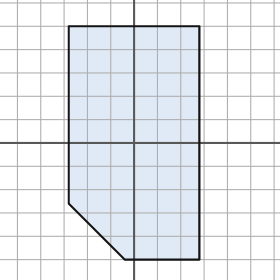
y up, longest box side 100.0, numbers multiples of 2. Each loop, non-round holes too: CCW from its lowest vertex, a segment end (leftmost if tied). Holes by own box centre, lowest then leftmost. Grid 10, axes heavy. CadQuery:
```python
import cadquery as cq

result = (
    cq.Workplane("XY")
    .moveTo(-4.0, -50.0)
    .lineTo(28.0, -50.0)
    .lineTo(28.0, 50.0)
    .lineTo(-28.0, 50.0)
    .lineTo(-28.0, -26.0)
    .close()
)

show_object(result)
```